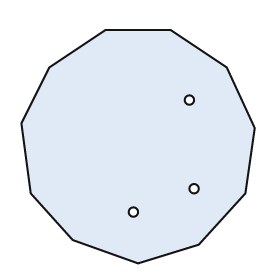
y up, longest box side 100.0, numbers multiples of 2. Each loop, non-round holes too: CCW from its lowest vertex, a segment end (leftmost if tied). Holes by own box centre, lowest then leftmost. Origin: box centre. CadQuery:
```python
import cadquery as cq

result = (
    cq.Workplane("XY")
    .moveTo(0.0, -50.0)
    .lineTo(26.0, -42.0)
    .lineTo(46.0, -20.0)
    .lineTo(50.0, 8.0)
    .lineTo(38.0, 34.0)
    .lineTo(14.0, 50.0)
    .lineTo(-14.0, 50.0)
    .lineTo(-38.0, 34.0)
    .lineTo(-50.0, 10.0)
    .lineTo(-46.0, -20.0)
    .lineTo(-28.0, -40.0)
    .close()
    .moveTo(-2.0, -28.0)
    .circle(2.0)
    .moveTo(24.0, -18.0)
    .circle(2.0)
    .moveTo(22.0, 20.0)
    .circle(2.0)
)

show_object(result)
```